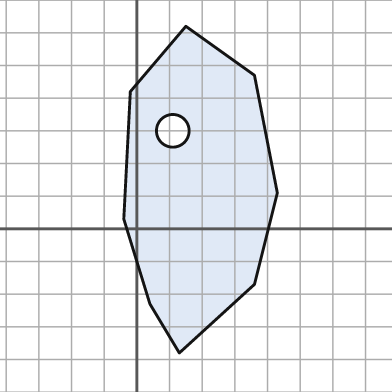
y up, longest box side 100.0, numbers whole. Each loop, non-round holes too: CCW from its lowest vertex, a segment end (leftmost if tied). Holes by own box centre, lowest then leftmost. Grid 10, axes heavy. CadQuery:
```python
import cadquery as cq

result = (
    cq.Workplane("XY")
    .moveTo(13.0, -38.0)
    .lineTo(36.0, -17.0)
    .lineTo(43.0, 11.0)
    .lineTo(36.0, 47.0)
    .lineTo(15.0, 62.0)
    .lineTo(-2.0, 42.0)
    .lineTo(-4.0, 3.0)
    .lineTo(4.0, -23.0)
    .close()
    .moveTo(11.0, 30.0)
    .circle(5.0)
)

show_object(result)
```